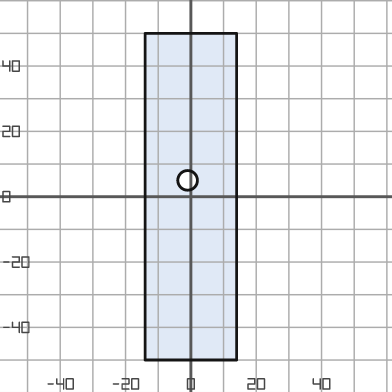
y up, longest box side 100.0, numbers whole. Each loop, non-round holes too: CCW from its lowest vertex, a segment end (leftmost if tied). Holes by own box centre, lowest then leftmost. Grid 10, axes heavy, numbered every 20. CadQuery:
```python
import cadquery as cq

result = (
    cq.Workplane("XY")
    .moveTo(-14.0, -50.0)
    .lineTo(14.0, -50.0)
    .lineTo(14.0, 50.0)
    .lineTo(-14.0, 50.0)
    .close()
    .moveTo(-1.0, 5.0)
    .circle(3.0)
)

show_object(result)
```